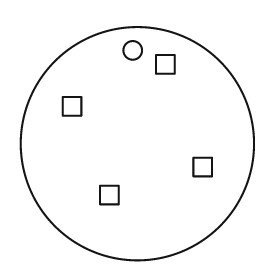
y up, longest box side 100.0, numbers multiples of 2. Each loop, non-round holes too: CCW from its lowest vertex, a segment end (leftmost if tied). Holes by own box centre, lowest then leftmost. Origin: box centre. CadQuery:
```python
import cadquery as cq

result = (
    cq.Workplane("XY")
    .moveTo(0.0, 0.0)
    .circle(50.0)
    .moveTo(-16.0, -26.0)
    .lineTo(-8.0, -26.0)
    .lineTo(-8.0, -18.0)
    .lineTo(-16.0, -18.0)
    .close()
    .moveTo(24.0, -14.0)
    .lineTo(32.0, -14.0)
    .lineTo(32.0, -6.0)
    .lineTo(24.0, -6.0)
    .close()
    .moveTo(-32.0, 12.0)
    .lineTo(-24.0, 12.0)
    .lineTo(-24.0, 20.0)
    .lineTo(-32.0, 20.0)
    .close()
    .moveTo(8.0, 30.0)
    .lineTo(16.0, 30.0)
    .lineTo(16.0, 38.0)
    .lineTo(8.0, 38.0)
    .close()
    .moveTo(-2.0, 40.0)
    .circle(4.0)
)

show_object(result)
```